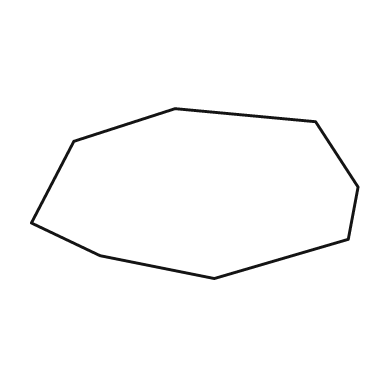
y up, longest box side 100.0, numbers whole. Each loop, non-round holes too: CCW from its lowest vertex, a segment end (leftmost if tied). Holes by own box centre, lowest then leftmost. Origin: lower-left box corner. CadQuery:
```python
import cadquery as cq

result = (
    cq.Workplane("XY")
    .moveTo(56.0, 0.0)
    .lineTo(97.0, 12.0)
    .lineTo(100.0, 28.0)
    .lineTo(87.0, 48.0)
    .lineTo(44.0, 52.0)
    .lineTo(13.0, 42.0)
    .lineTo(0.0, 17.0)
    .lineTo(21.0, 7.0)
    .close()
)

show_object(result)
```